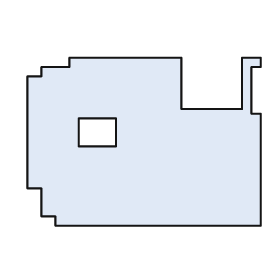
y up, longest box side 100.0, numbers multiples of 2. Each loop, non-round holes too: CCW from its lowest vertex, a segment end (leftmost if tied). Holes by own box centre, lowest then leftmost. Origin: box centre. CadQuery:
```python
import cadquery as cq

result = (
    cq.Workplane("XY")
    .moveTo(-38.0, -36.0)
    .lineTo(50.0, -36.0)
    .lineTo(50.0, 12.0)
    .lineTo(46.0, 12.0)
    .lineTo(46.0, 32.0)
    .lineTo(50.0, 32.0)
    .lineTo(50.0, 36.0)
    .lineTo(42.0, 36.0)
    .lineTo(42.0, 14.0)
    .lineTo(16.0, 14.0)
    .lineTo(16.0, 36.0)
    .lineTo(-32.0, 36.0)
    .lineTo(-32.0, 32.0)
    .lineTo(-44.0, 32.0)
    .lineTo(-44.0, 28.0)
    .lineTo(-50.0, 28.0)
    .lineTo(-50.0, -20.0)
    .lineTo(-44.0, -20.0)
    .lineTo(-44.0, -32.0)
    .lineTo(-38.0, -32.0)
    .close()
    .moveTo(-28.0, -2.0)
    .lineTo(-12.0, -2.0)
    .lineTo(-12.0, 10.0)
    .lineTo(-28.0, 10.0)
    .close()
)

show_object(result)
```